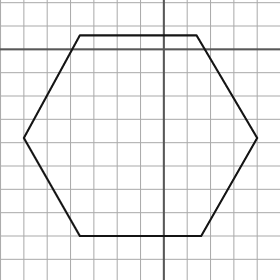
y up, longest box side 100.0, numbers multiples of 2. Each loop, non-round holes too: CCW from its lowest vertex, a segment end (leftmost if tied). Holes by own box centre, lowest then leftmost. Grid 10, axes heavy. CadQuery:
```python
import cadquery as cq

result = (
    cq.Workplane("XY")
    .moveTo(-36.0, -80.0)
    .lineTo(16.0, -80.0)
    .lineTo(40.0, -38.0)
    .lineTo(14.0, 6.0)
    .lineTo(-36.0, 6.0)
    .lineTo(-60.0, -38.0)
    .close()
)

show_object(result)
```